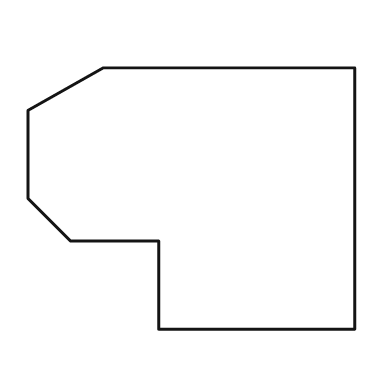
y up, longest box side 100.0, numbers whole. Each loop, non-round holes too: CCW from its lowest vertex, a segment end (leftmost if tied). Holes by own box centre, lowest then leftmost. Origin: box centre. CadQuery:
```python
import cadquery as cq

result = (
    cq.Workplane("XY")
    .moveTo(-10.0, -40.0)
    .lineTo(50.0, -40.0)
    .lineTo(50.0, 40.0)
    .lineTo(-27.0, 40.0)
    .lineTo(-50.0, 27.0)
    .lineTo(-50.0, 0.0)
    .lineTo(-37.0, -13.0)
    .lineTo(-10.0, -13.0)
    .close()
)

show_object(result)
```